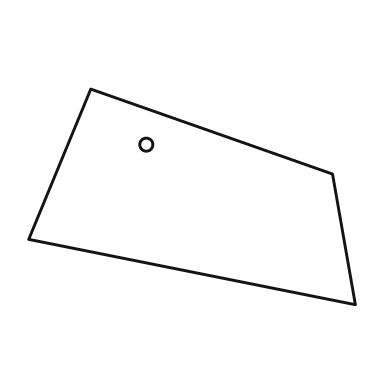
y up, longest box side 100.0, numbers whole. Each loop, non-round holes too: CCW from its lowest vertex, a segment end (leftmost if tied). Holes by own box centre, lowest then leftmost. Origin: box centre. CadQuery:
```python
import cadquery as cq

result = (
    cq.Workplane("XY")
    .moveTo(50.0, -33.0)
    .lineTo(43.0, 7.0)
    .lineTo(-31.0, 33.0)
    .lineTo(-50.0, -13.0)
    .close()
    .moveTo(-14.0, 16.0)
    .circle(2.0)
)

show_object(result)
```